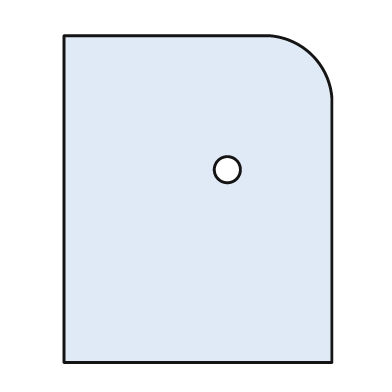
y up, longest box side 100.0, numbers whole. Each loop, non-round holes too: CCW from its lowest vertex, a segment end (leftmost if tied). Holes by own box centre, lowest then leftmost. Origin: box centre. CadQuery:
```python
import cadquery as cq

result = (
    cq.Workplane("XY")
    .moveTo(-41.0, -50.0)
    .lineTo(41.0, -50.0)
    .lineTo(41.0, 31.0)
    .threePointArc((35.0, 44.0), (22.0, 50.0))
    .lineTo(-41.0, 50.0)
    .close()
    .moveTo(9.0, 9.0)
    .circle(4.0)
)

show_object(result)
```